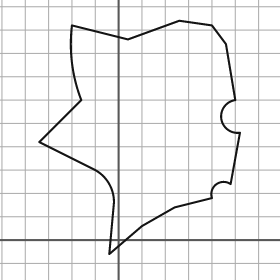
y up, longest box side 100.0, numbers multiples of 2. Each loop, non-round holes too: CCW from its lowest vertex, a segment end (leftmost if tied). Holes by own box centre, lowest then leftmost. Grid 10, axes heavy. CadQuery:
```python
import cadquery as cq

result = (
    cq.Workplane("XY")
    .moveTo(-4.0, -6.0)
    .lineTo(10.0, 6.0)
    .lineTo(24.0, 14.0)
    .lineTo(40.0, 18.0)
    .threePointArc((42.0, 24.0), (48.0, 24.0))
    .lineTo(52.0, 46.0)
    .threePointArc((44.0, 52.0), (50.0, 60.0))
    .lineTo(46.0, 84.0)
    .lineTo(40.0, 92.0)
    .lineTo(26.0, 94.0)
    .lineTo(4.0, 86.0)
    .lineTo(-20.0, 92.0)
    .threePointArc((-20.0, 76.0), (-16.0, 60.0))
    .lineTo(-34.0, 42.0)
    .lineTo(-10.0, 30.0)
    .threePointArc((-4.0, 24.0), (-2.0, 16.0))
    .close()
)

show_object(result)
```